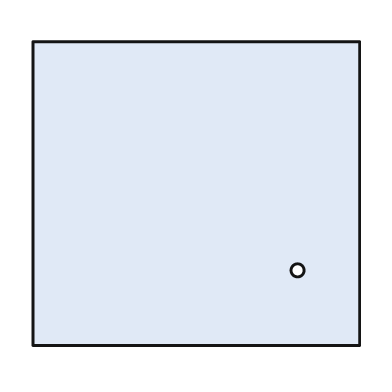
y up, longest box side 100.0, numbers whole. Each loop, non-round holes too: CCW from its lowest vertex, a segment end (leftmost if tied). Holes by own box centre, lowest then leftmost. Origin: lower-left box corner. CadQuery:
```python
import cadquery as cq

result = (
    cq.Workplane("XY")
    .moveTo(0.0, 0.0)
    .lineTo(100.0, 0.0)
    .lineTo(100.0, 93.0)
    .lineTo(0.0, 93.0)
    .close()
    .moveTo(81.0, 23.0)
    .circle(2.0)
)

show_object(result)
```